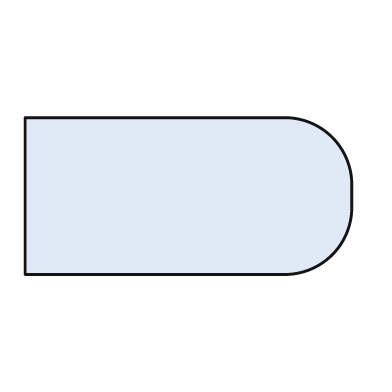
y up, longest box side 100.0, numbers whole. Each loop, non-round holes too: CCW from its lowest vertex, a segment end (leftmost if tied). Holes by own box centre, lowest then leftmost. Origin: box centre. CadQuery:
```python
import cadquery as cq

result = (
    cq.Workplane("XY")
    .moveTo(-50.0, -24.0)
    .lineTo(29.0, -24.0)
    .threePointArc((44.0, -18.0), (50.0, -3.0))
    .lineTo(50.0, 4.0)
    .threePointArc((44.0, 18.0), (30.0, 24.0))
    .lineTo(-50.0, 24.0)
    .close()
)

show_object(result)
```